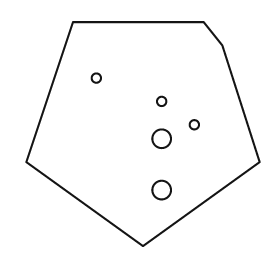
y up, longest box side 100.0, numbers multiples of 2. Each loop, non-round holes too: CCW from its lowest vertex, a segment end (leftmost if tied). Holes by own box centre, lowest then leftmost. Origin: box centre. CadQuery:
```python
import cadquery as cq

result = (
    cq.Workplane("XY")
    .moveTo(0.0, -48.0)
    .lineTo(50.0, -12.0)
    .lineTo(34.0, 38.0)
    .lineTo(26.0, 48.0)
    .lineTo(-30.0, 48.0)
    .lineTo(-50.0, -12.0)
    .close()
    .moveTo(8.0, -24.0)
    .circle(4.0)
    .moveTo(8.0, -2.0)
    .circle(4.0)
    .moveTo(22.0, 4.0)
    .circle(2.0)
    .moveTo(8.0, 14.0)
    .circle(2.0)
    .moveTo(-20.0, 24.0)
    .circle(2.0)
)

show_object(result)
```